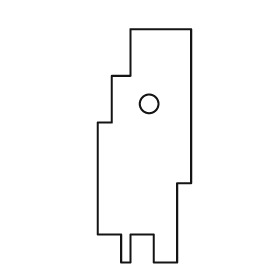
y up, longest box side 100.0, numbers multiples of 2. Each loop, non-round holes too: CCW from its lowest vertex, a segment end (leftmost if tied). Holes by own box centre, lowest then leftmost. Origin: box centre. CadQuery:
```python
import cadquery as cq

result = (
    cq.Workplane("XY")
    .moveTo(-10.0, -50.0)
    .lineTo(-6.0, -50.0)
    .lineTo(-6.0, -38.0)
    .lineTo(4.0, -38.0)
    .lineTo(4.0, -50.0)
    .lineTo(14.0, -50.0)
    .lineTo(14.0, -16.0)
    .lineTo(20.0, -16.0)
    .lineTo(20.0, 50.0)
    .lineTo(-6.0, 50.0)
    .lineTo(-6.0, 30.0)
    .lineTo(-14.0, 30.0)
    .lineTo(-14.0, 10.0)
    .lineTo(-20.0, 10.0)
    .lineTo(-20.0, -38.0)
    .lineTo(-10.0, -38.0)
    .close()
    .moveTo(2.0, 18.0)
    .circle(4.0)
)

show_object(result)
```